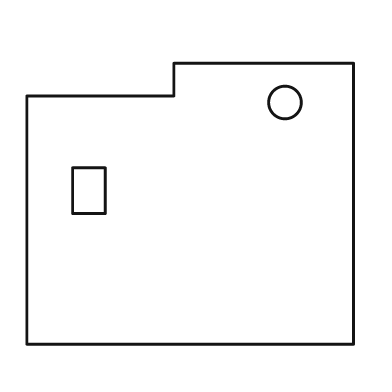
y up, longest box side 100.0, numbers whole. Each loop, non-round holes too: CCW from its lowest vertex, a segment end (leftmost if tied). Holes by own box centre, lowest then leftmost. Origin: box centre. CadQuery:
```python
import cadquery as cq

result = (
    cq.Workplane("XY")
    .moveTo(-50.0, -43.0)
    .lineTo(50.0, -43.0)
    .lineTo(50.0, 43.0)
    .lineTo(-5.0, 43.0)
    .lineTo(-5.0, 33.0)
    .lineTo(-50.0, 33.0)
    .close()
    .moveTo(-36.0, -3.0)
    .lineTo(-26.0, -3.0)
    .lineTo(-26.0, 11.0)
    .lineTo(-36.0, 11.0)
    .close()
    .moveTo(29.0, 31.0)
    .circle(5.0)
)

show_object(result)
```